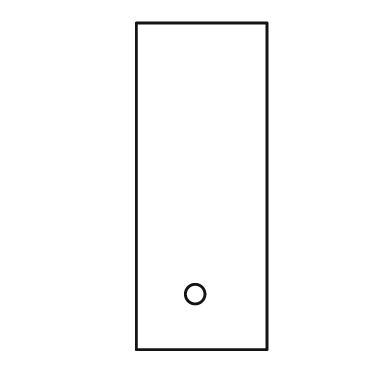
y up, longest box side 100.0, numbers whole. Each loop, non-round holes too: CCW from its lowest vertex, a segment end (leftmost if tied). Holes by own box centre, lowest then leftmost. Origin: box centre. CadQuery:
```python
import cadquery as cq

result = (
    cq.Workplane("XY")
    .moveTo(-20.0, -50.0)
    .lineTo(20.0, -50.0)
    .lineTo(20.0, 50.0)
    .lineTo(-20.0, 50.0)
    .close()
    .moveTo(-2.0, -33.0)
    .circle(3.0)
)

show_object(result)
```